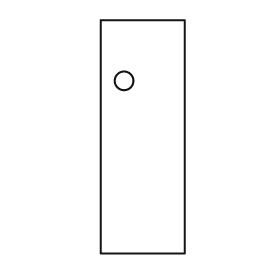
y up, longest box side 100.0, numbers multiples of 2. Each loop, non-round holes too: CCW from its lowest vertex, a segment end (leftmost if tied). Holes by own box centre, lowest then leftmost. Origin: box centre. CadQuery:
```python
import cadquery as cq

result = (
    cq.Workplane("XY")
    .moveTo(-18.0, -50.0)
    .lineTo(18.0, -50.0)
    .lineTo(18.0, 50.0)
    .lineTo(-18.0, 50.0)
    .close()
    .moveTo(-8.0, 24.0)
    .circle(4.0)
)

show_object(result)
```